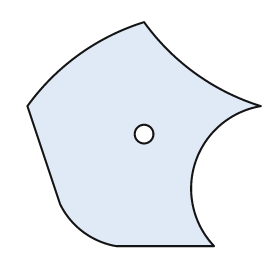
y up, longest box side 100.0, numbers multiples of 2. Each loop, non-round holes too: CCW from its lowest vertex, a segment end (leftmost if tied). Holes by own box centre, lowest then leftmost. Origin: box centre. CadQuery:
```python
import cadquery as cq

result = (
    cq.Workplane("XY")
    .moveTo(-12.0, -48.0)
    .lineTo(30.0, -48.0)
    .threePointArc((22.0, -12.0), (50.0, 12.0))
    .threePointArc((22.0, 26.0), (0.0, 48.0))
    .threePointArc((-28.0, 34.0), (-50.0, 12.0))
    .lineTo(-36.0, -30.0)
    .threePointArc((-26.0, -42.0), (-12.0, -48.0))
    .close()
    .moveTo(0.0, 0.0)
    .circle(4.0)
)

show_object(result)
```